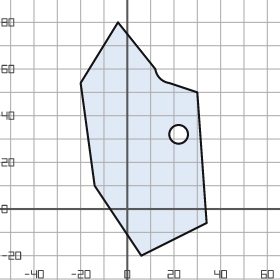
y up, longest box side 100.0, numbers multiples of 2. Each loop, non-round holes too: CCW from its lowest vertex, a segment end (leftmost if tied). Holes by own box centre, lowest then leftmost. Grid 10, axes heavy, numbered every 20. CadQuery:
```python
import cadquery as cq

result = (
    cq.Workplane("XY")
    .moveTo(6.0, -20.0)
    .lineTo(34.0, -6.0)
    .lineTo(30.0, 50.0)
    .lineTo(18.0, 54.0)
    .threePointArc((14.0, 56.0), (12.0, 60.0))
    .lineTo(-4.0, 80.0)
    .lineTo(-20.0, 54.0)
    .lineTo(-14.0, 10.0)
    .close()
    .moveTo(22.0, 32.0)
    .circle(4.0)
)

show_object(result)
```